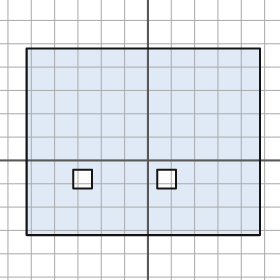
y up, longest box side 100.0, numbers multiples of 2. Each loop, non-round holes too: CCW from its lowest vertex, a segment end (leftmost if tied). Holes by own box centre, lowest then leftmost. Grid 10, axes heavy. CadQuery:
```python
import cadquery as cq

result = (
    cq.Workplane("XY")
    .moveTo(-52.0, -32.0)
    .lineTo(48.0, -32.0)
    .lineTo(48.0, 48.0)
    .lineTo(-52.0, 48.0)
    .close()
    .moveTo(-32.0, -12.0)
    .lineTo(-24.0, -12.0)
    .lineTo(-24.0, -4.0)
    .lineTo(-32.0, -4.0)
    .close()
    .moveTo(4.0, -12.0)
    .lineTo(12.0, -12.0)
    .lineTo(12.0, -4.0)
    .lineTo(4.0, -4.0)
    .close()
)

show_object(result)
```